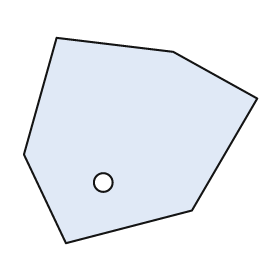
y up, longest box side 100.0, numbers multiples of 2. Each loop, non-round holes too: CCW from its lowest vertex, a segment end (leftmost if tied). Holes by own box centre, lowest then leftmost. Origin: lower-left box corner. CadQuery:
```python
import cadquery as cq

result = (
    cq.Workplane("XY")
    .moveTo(18.0, 0.0)
    .lineTo(72.0, 14.0)
    .lineTo(100.0, 62.0)
    .lineTo(64.0, 82.0)
    .lineTo(14.0, 88.0)
    .lineTo(0.0, 38.0)
    .close()
    .moveTo(34.0, 26.0)
    .circle(4.0)
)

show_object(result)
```